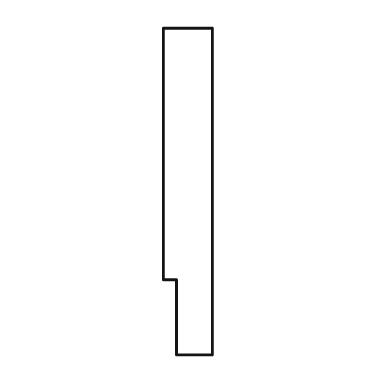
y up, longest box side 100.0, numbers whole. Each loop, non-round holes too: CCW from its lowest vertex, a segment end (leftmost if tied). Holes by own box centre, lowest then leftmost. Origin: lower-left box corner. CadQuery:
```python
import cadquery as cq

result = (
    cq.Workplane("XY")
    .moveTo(4.0, 0.0)
    .lineTo(15.0, 0.0)
    .lineTo(15.0, 100.0)
    .lineTo(0.0, 100.0)
    .lineTo(0.0, 23.0)
    .lineTo(4.0, 23.0)
    .close()
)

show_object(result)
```